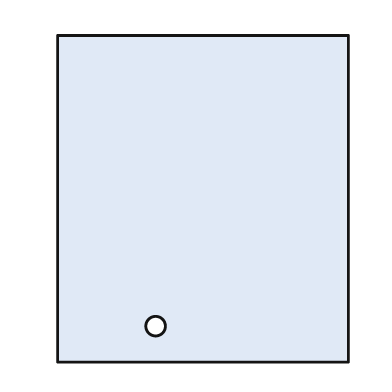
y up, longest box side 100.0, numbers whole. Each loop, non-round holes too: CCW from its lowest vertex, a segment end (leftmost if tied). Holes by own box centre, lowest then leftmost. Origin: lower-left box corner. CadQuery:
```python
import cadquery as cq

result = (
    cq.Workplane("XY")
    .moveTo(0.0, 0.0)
    .lineTo(89.0, 0.0)
    .lineTo(89.0, 100.0)
    .lineTo(0.0, 100.0)
    .close()
    .moveTo(30.0, 11.0)
    .circle(3.0)
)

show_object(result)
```